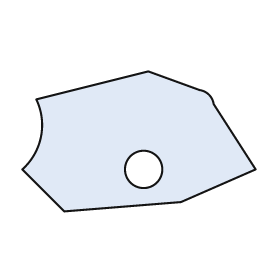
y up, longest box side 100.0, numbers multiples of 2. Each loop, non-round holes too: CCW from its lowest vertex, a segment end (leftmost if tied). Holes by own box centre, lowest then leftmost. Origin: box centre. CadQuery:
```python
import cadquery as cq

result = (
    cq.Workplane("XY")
    .moveTo(-32.0, -30.0)
    .lineTo(18.0, -26.0)
    .lineTo(50.0, -12.0)
    .lineTo(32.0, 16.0)
    .threePointArc((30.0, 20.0), (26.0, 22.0))
    .lineTo(4.0, 30.0)
    .lineTo(-44.0, 18.0)
    .threePointArc((-42.0, 2.0), (-50.0, -12.0))
    .close()
    .moveTo(2.0, -12.0)
    .circle(8.0)
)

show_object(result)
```